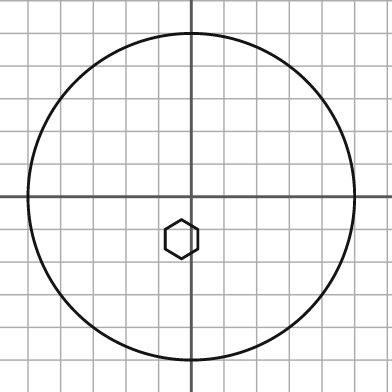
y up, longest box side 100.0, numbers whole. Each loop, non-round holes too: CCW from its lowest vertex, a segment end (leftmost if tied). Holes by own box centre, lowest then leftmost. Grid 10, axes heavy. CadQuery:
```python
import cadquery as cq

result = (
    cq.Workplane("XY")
    .moveTo(0.0, 0.0)
    .circle(50.0)
    .moveTo(-3.0, -19.0)
    .lineTo(2.0, -16.0)
    .lineTo(2.0, -10.0)
    .lineTo(-3.0, -7.0)
    .lineTo(-8.0, -10.0)
    .lineTo(-8.0, -16.0)
    .close()
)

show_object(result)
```